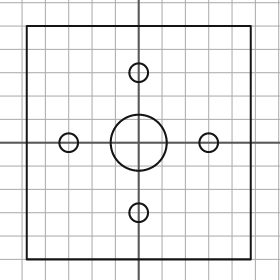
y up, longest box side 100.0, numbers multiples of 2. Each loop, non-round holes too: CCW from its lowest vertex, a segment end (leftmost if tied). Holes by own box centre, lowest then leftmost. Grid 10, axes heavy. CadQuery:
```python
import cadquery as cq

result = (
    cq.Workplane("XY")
    .moveTo(-48.0, -50.0)
    .lineTo(48.0, -50.0)
    .lineTo(48.0, 50.0)
    .lineTo(-48.0, 50.0)
    .close()
    .moveTo(0.0, -30.0)
    .circle(4.0)
    .moveTo(-30.0, 0.0)
    .circle(4.0)
    .moveTo(0.0, 0.0)
    .circle(12.0)
    .moveTo(30.0, 0.0)
    .circle(4.0)
    .moveTo(0.0, 30.0)
    .circle(4.0)
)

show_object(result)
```